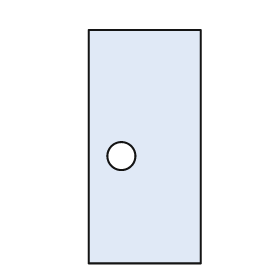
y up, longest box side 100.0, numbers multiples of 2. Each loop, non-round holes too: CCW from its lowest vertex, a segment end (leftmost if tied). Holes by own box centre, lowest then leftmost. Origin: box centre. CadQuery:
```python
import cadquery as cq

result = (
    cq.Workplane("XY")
    .moveTo(-24.0, -50.0)
    .lineTo(24.0, -50.0)
    .lineTo(24.0, 50.0)
    .lineTo(-24.0, 50.0)
    .close()
    .moveTo(-10.0, -4.0)
    .circle(6.0)
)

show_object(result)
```